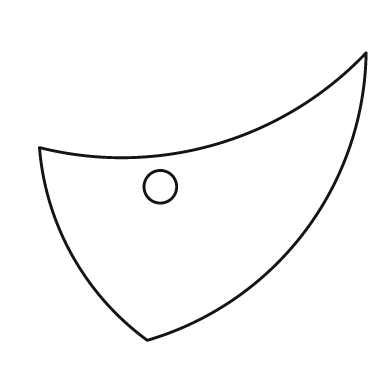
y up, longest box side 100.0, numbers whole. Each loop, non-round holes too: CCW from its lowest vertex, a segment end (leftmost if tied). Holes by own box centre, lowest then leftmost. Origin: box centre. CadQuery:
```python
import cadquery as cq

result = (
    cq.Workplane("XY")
    .moveTo(-17.0, -44.0)
    .threePointArc((31.0, -11.0), (50.0, 44.0))
    .threePointArc((4.0, 16.0), (-50.0, 15.0))
    .threePointArc((-40.0, -18.0), (-17.0, -44.0))
    .close()
    .moveTo(-13.0, 3.0)
    .circle(5.0)
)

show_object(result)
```